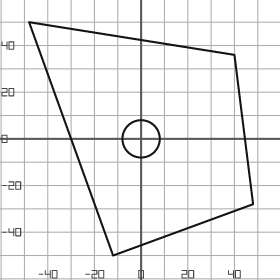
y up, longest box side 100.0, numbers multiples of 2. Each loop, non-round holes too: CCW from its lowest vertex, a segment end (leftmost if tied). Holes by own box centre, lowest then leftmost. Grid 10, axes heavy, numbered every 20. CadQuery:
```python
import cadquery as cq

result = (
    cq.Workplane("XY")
    .moveTo(-12.0, -50.0)
    .lineTo(48.0, -28.0)
    .lineTo(40.0, 36.0)
    .lineTo(-48.0, 50.0)
    .close()
    .moveTo(0.0, 0.0)
    .circle(8.0)
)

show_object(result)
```